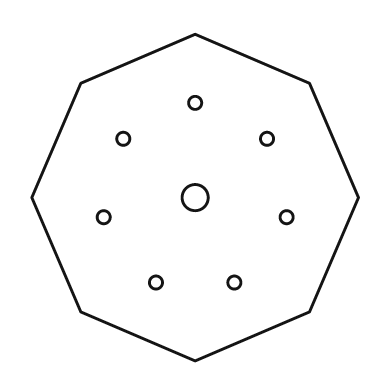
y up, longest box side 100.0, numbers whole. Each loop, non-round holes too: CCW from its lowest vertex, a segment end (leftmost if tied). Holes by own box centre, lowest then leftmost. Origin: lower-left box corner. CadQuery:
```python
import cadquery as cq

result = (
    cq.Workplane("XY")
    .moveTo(50.0, 0.0)
    .lineTo(85.0, 15.0)
    .lineTo(100.0, 50.0)
    .lineTo(85.0, 85.0)
    .lineTo(50.0, 100.0)
    .lineTo(15.0, 85.0)
    .lineTo(0.0, 50.0)
    .lineTo(15.0, 15.0)
    .close()
    .moveTo(38.0, 24.0)
    .circle(2.0)
    .moveTo(62.0, 24.0)
    .circle(2.0)
    .moveTo(22.0, 44.0)
    .circle(2.0)
    .moveTo(78.0, 44.0)
    .circle(2.0)
    .moveTo(50.0, 50.0)
    .circle(4.0)
    .moveTo(28.0, 68.0)
    .circle(2.0)
    .moveTo(72.0, 68.0)
    .circle(2.0)
    .moveTo(50.0, 79.0)
    .circle(2.0)
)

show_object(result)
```